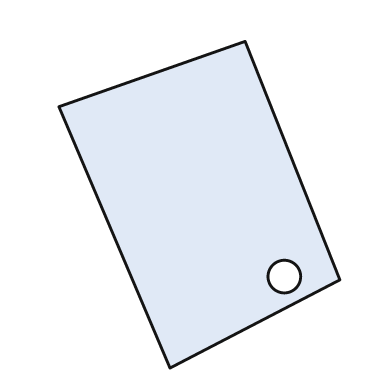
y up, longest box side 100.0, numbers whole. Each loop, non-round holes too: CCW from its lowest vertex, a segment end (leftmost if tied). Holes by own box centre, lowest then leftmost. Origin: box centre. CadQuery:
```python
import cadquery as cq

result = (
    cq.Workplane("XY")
    .moveTo(-9.0, -50.0)
    .lineTo(43.0, -23.0)
    .lineTo(14.0, 50.0)
    .lineTo(-43.0, 30.0)
    .close()
    .moveTo(26.0, -22.0)
    .circle(5.0)
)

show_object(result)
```